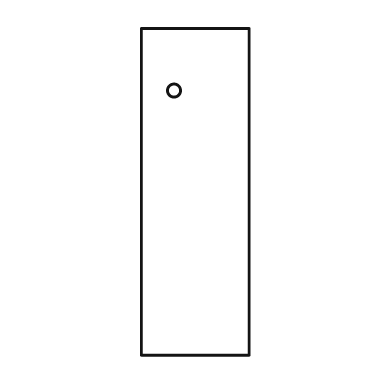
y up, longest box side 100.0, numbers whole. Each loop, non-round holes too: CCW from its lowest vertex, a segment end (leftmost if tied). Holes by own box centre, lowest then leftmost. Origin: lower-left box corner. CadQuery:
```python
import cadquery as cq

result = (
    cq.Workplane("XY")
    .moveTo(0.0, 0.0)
    .lineTo(33.0, 0.0)
    .lineTo(33.0, 100.0)
    .lineTo(0.0, 100.0)
    .close()
    .moveTo(10.0, 81.0)
    .circle(2.0)
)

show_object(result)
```